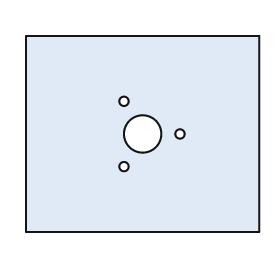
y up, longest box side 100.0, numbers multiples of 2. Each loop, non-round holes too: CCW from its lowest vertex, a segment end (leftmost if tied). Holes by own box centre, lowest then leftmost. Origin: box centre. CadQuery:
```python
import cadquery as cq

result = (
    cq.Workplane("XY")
    .moveTo(-50.0, -42.0)
    .lineTo(50.0, -42.0)
    .lineTo(50.0, 42.0)
    .lineTo(-50.0, 42.0)
    .close()
    .moveTo(-8.0, -14.0)
    .circle(2.0)
    .moveTo(0.0, 0.0)
    .circle(8.0)
    .moveTo(16.0, 0.0)
    .circle(2.0)
    .moveTo(-8.0, 14.0)
    .circle(2.0)
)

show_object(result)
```